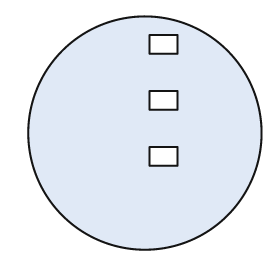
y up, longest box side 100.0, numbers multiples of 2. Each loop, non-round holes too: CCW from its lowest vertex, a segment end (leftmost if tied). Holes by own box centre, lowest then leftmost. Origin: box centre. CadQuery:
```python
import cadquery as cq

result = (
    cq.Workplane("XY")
    .moveTo(0.0, 0.0)
    .circle(50.0)
    .moveTo(2.0, -14.0)
    .lineTo(14.0, -14.0)
    .lineTo(14.0, -6.0)
    .lineTo(2.0, -6.0)
    .close()
    .moveTo(2.0, 10.0)
    .lineTo(14.0, 10.0)
    .lineTo(14.0, 18.0)
    .lineTo(2.0, 18.0)
    .close()
    .moveTo(2.0, 34.0)
    .lineTo(14.0, 34.0)
    .lineTo(14.0, 42.0)
    .lineTo(2.0, 42.0)
    .close()
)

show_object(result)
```